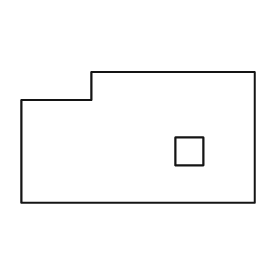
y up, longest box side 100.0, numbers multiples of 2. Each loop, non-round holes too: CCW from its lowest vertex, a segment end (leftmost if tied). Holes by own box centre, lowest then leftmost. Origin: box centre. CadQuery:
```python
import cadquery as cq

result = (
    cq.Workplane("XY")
    .moveTo(-50.0, -28.0)
    .lineTo(50.0, -28.0)
    .lineTo(50.0, 28.0)
    .lineTo(-20.0, 28.0)
    .lineTo(-20.0, 16.0)
    .lineTo(-50.0, 16.0)
    .close()
    .moveTo(16.0, -12.0)
    .lineTo(28.0, -12.0)
    .lineTo(28.0, 0.0)
    .lineTo(16.0, 0.0)
    .close()
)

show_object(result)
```